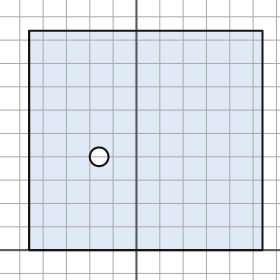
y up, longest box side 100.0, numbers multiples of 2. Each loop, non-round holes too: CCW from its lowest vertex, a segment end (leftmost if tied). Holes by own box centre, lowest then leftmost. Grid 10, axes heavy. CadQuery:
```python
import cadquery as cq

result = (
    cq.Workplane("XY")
    .moveTo(-46.0, 0.0)
    .lineTo(54.0, 0.0)
    .lineTo(54.0, 94.0)
    .lineTo(-46.0, 94.0)
    .close()
    .moveTo(-16.0, 40.0)
    .circle(4.0)
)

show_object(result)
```